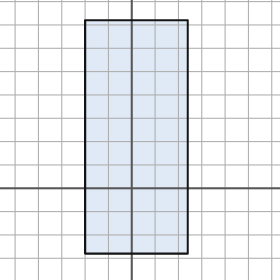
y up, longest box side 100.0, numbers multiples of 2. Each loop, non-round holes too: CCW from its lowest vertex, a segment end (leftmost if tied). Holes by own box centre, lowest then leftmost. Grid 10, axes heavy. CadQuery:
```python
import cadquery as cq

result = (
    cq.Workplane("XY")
    .moveTo(-20.0, -28.0)
    .lineTo(24.0, -28.0)
    .lineTo(24.0, 72.0)
    .lineTo(-20.0, 72.0)
    .close()
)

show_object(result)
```